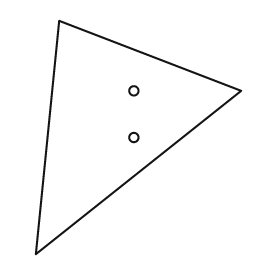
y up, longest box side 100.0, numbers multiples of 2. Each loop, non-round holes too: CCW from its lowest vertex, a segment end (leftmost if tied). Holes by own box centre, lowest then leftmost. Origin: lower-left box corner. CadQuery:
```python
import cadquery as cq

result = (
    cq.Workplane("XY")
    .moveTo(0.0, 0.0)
    .lineTo(88.0, 70.0)
    .lineTo(10.0, 100.0)
    .close()
    .moveTo(42.0, 50.0)
    .circle(2.0)
    .moveTo(42.0, 70.0)
    .circle(2.0)
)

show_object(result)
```